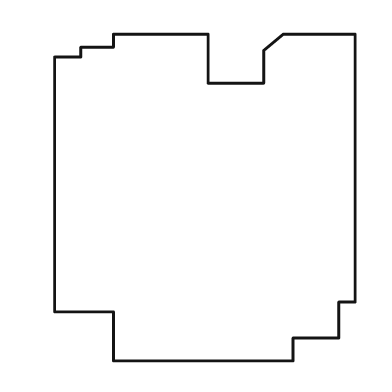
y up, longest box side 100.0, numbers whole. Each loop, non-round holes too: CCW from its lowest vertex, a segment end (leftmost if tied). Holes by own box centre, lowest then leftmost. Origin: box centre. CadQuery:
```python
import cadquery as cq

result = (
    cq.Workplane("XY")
    .moveTo(-28.0, -50.0)
    .lineTo(27.0, -50.0)
    .lineTo(27.0, -43.0)
    .lineTo(41.0, -43.0)
    .lineTo(41.0, -32.0)
    .lineTo(46.0, -32.0)
    .lineTo(46.0, 50.0)
    .lineTo(24.0, 50.0)
    .lineTo(18.0, 45.0)
    .lineTo(18.0, 35.0)
    .lineTo(1.0, 35.0)
    .lineTo(1.0, 50.0)
    .lineTo(-28.0, 50.0)
    .lineTo(-28.0, 46.0)
    .lineTo(-38.0, 46.0)
    .lineTo(-38.0, 43.0)
    .lineTo(-46.0, 43.0)
    .lineTo(-46.0, -35.0)
    .lineTo(-28.0, -35.0)
    .close()
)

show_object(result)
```